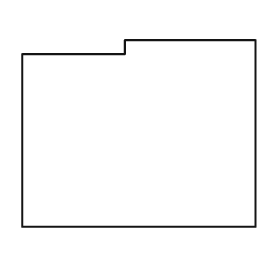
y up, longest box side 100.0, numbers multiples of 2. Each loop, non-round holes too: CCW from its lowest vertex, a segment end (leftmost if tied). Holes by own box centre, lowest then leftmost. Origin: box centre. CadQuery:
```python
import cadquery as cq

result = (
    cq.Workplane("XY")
    .moveTo(-50.0, -40.0)
    .lineTo(50.0, -40.0)
    .lineTo(50.0, 40.0)
    .lineTo(-6.0, 40.0)
    .lineTo(-6.0, 34.0)
    .lineTo(-50.0, 34.0)
    .close()
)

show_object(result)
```